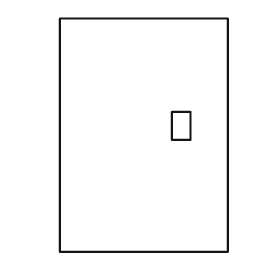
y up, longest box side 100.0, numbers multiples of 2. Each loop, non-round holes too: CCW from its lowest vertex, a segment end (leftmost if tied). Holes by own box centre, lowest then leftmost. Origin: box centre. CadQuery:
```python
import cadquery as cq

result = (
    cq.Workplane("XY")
    .moveTo(-36.0, -50.0)
    .lineTo(36.0, -50.0)
    .lineTo(36.0, 50.0)
    .lineTo(-36.0, 50.0)
    .close()
    .moveTo(12.0, -2.0)
    .lineTo(20.0, -2.0)
    .lineTo(20.0, 10.0)
    .lineTo(12.0, 10.0)
    .close()
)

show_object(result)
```